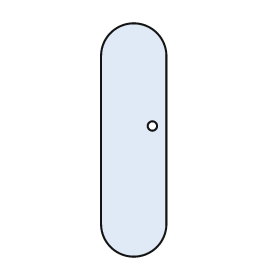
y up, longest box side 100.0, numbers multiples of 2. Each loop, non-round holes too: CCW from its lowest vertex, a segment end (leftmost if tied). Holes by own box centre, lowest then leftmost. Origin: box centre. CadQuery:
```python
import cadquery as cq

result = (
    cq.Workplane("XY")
    .moveTo(-14.0, -36.0)
    .threePointArc((0.0, -50.0), (14.0, -36.0))
    .lineTo(14.0, 36.0)
    .threePointArc((0.0, 50.0), (-14.0, 36.0))
    .close()
    .moveTo(8.0, 6.0)
    .circle(2.0)
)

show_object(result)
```